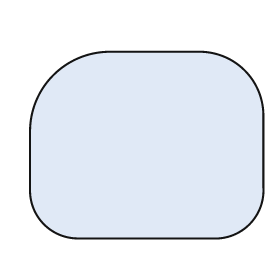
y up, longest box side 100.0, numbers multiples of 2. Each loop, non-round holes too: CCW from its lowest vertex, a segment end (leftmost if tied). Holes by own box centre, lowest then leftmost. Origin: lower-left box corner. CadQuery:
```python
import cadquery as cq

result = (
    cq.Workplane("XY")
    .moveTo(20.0, 0.0)
    .lineTo(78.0, 0.0)
    .threePointArc((94.0, 6.0), (100.0, 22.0))
    .lineTo(100.0, 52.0)
    .threePointArc((92.0, 72.0), (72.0, 80.0))
    .lineTo(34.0, 80.0)
    .threePointArc((10.0, 70.0), (0.0, 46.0))
    .lineTo(0.0, 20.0)
    .threePointArc((6.0, 6.0), (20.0, 0.0))
    .close()
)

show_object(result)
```